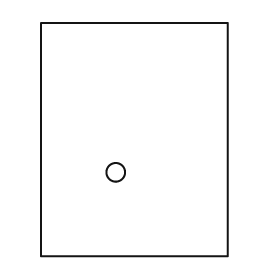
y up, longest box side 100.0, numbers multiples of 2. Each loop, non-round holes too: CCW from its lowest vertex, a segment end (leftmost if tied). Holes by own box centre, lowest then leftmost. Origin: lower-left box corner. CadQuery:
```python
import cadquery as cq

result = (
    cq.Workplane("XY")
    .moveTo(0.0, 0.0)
    .lineTo(80.0, 0.0)
    .lineTo(80.0, 100.0)
    .lineTo(0.0, 100.0)
    .close()
    .moveTo(32.0, 36.0)
    .circle(4.0)
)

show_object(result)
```